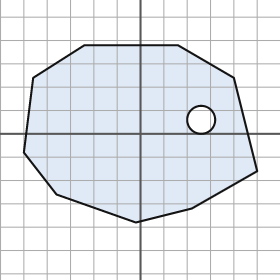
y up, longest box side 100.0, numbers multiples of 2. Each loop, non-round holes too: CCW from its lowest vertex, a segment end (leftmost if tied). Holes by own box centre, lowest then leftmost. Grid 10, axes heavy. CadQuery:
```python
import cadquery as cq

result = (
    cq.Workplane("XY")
    .moveTo(-2.0, -38.0)
    .lineTo(22.0, -32.0)
    .lineTo(50.0, -16.0)
    .lineTo(40.0, 24.0)
    .lineTo(16.0, 38.0)
    .lineTo(-24.0, 38.0)
    .lineTo(-46.0, 24.0)
    .lineTo(-50.0, -8.0)
    .lineTo(-36.0, -26.0)
    .close()
    .moveTo(26.0, 6.0)
    .circle(6.0)
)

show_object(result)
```